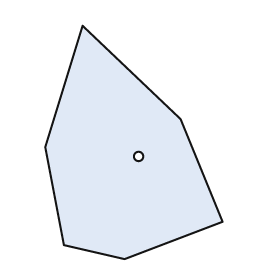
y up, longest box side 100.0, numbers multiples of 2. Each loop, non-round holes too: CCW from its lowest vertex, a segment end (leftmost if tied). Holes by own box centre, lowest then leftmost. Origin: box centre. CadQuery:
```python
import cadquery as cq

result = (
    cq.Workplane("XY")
    .moveTo(-4.0, -50.0)
    .lineTo(38.0, -34.0)
    .lineTo(20.0, 10.0)
    .lineTo(-22.0, 50.0)
    .lineTo(-38.0, -2.0)
    .lineTo(-30.0, -44.0)
    .close()
    .moveTo(2.0, -6.0)
    .circle(2.0)
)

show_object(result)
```